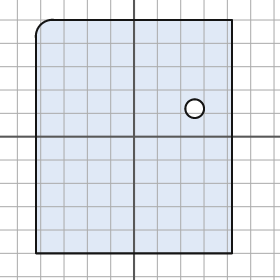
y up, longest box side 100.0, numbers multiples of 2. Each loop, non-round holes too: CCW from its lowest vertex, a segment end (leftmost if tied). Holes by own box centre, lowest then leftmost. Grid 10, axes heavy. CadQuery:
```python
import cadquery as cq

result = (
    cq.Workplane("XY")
    .moveTo(-42.0, -50.0)
    .lineTo(42.0, -50.0)
    .lineTo(42.0, 50.0)
    .lineTo(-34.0, 50.0)
    .threePointArc((-40.0, 48.0), (-42.0, 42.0))
    .close()
    .moveTo(26.0, 12.0)
    .circle(4.0)
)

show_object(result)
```